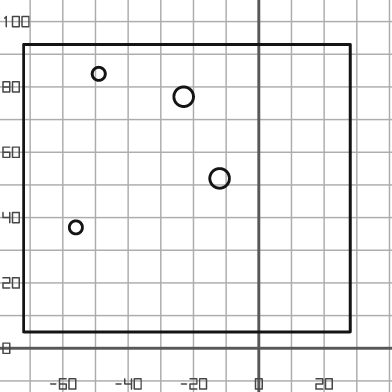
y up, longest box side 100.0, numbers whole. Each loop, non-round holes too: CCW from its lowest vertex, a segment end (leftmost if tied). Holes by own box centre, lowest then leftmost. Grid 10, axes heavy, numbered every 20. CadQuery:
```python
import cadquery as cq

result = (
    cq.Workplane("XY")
    .moveTo(-72.0, 5.0)
    .lineTo(28.0, 5.0)
    .lineTo(28.0, 93.0)
    .lineTo(-72.0, 93.0)
    .close()
    .moveTo(-56.0, 37.0)
    .circle(2.0)
    .moveTo(-12.0, 52.0)
    .circle(3.0)
    .moveTo(-23.0, 77.0)
    .circle(3.0)
    .moveTo(-49.0, 84.0)
    .circle(2.0)
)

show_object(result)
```